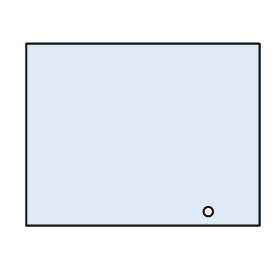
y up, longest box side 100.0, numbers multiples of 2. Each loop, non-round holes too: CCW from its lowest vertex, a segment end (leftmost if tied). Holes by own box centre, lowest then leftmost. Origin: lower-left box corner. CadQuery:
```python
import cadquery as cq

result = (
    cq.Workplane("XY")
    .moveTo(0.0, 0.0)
    .lineTo(100.0, 0.0)
    .lineTo(100.0, 78.0)
    .lineTo(0.0, 78.0)
    .close()
    .moveTo(78.0, 6.0)
    .circle(2.0)
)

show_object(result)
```